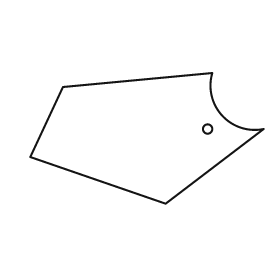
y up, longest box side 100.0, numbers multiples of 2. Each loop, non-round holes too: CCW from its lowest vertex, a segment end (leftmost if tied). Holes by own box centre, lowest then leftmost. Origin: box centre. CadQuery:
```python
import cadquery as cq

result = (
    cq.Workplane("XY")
    .moveTo(8.0, -28.0)
    .lineTo(50.0, 4.0)
    .threePointArc((32.0, 10.0), (28.0, 28.0))
    .lineTo(-36.0, 22.0)
    .lineTo(-50.0, -8.0)
    .close()
    .moveTo(26.0, 4.0)
    .circle(2.0)
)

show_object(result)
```